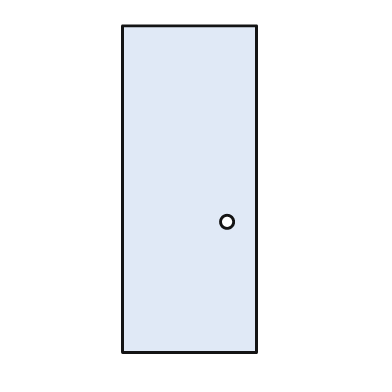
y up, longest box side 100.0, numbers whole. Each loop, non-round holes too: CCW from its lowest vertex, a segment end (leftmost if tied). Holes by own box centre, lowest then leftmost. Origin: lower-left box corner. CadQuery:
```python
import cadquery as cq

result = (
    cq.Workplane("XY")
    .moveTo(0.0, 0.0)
    .lineTo(41.0, 0.0)
    .lineTo(41.0, 100.0)
    .lineTo(0.0, 100.0)
    .close()
    .moveTo(32.0, 40.0)
    .circle(2.0)
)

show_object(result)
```